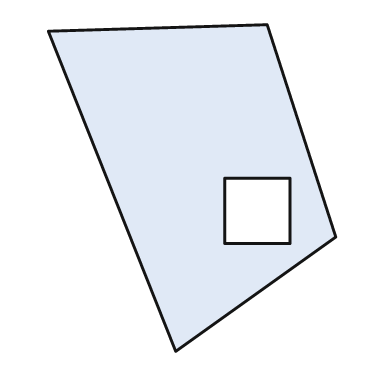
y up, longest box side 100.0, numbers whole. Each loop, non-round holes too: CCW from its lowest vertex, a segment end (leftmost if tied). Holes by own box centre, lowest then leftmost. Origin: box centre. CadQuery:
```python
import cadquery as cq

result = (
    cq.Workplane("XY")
    .moveTo(-5.0, -50.0)
    .lineTo(44.0, -15.0)
    .lineTo(23.0, 50.0)
    .lineTo(-44.0, 48.0)
    .close()
    .moveTo(10.0, -17.0)
    .lineTo(30.0, -17.0)
    .lineTo(30.0, 3.0)
    .lineTo(10.0, 3.0)
    .close()
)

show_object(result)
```